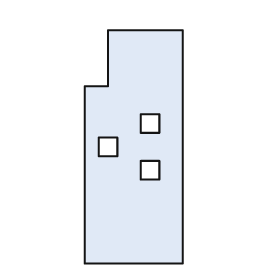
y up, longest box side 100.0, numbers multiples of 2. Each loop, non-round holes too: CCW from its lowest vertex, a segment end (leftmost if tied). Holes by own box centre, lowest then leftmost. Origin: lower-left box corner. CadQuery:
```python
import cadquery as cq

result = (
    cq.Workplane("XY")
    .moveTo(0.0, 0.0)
    .lineTo(42.0, 0.0)
    .lineTo(42.0, 100.0)
    .lineTo(10.0, 100.0)
    .lineTo(10.0, 76.0)
    .lineTo(0.0, 76.0)
    .close()
    .moveTo(24.0, 36.0)
    .lineTo(32.0, 36.0)
    .lineTo(32.0, 44.0)
    .lineTo(24.0, 44.0)
    .close()
    .moveTo(6.0, 46.0)
    .lineTo(14.0, 46.0)
    .lineTo(14.0, 54.0)
    .lineTo(6.0, 54.0)
    .close()
    .moveTo(24.0, 56.0)
    .lineTo(32.0, 56.0)
    .lineTo(32.0, 64.0)
    .lineTo(24.0, 64.0)
    .close()
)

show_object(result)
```